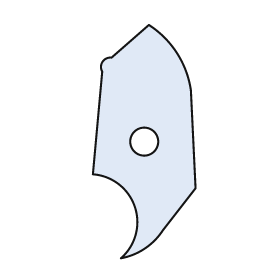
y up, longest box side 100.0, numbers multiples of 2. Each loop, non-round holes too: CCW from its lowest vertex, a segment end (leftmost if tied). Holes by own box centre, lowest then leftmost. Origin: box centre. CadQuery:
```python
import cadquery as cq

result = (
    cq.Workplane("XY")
    .moveTo(-10.0, -50.0)
    .threePointArc((0.0, -46.0), (8.0, -38.0))
    .lineTo(22.0, -20.0)
    .lineTo(20.0, 22.0)
    .threePointArc((14.0, 38.0), (2.0, 50.0))
    .lineTo(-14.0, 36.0)
    .threePointArc((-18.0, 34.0), (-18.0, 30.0))
    .lineTo(-22.0, -14.0)
    .threePointArc((-4.0, -28.0), (-10.0, -50.0))
    .close()
    .moveTo(0.0, 0.0)
    .circle(6.0)
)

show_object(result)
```